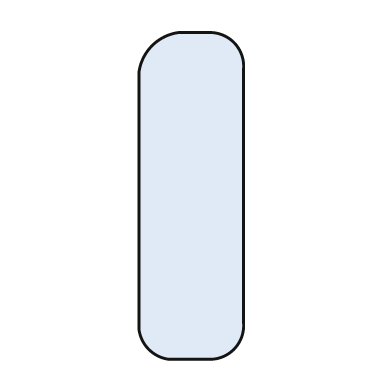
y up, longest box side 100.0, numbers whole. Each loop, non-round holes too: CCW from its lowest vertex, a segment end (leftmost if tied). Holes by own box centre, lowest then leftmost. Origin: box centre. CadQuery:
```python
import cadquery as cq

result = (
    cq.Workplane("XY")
    .moveTo(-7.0, -50.0)
    .lineTo(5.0, -50.0)
    .threePointArc((13.0, -47.0), (16.0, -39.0))
    .lineTo(16.0, 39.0)
    .threePointArc((13.0, 47.0), (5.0, 50.0))
    .lineTo(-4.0, 50.0)
    .threePointArc((-12.0, 46.0), (-16.0, 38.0))
    .lineTo(-16.0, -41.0)
    .threePointArc((-13.0, -47.0), (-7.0, -50.0))
    .close()
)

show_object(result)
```